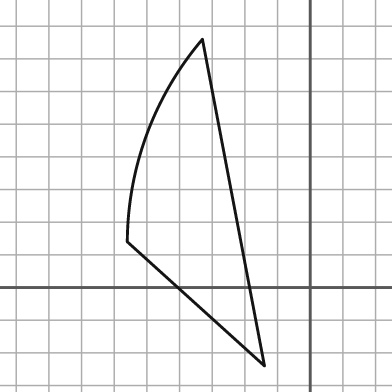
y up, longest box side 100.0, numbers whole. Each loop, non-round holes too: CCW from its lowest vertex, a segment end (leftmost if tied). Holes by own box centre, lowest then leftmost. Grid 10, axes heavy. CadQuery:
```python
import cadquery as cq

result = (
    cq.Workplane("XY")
    .moveTo(-14.0, -24.0)
    .lineTo(-33.0, 76.0)
    .threePointArc((-50.0, 47.0), (-56.0, 14.0))
    .close()
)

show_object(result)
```